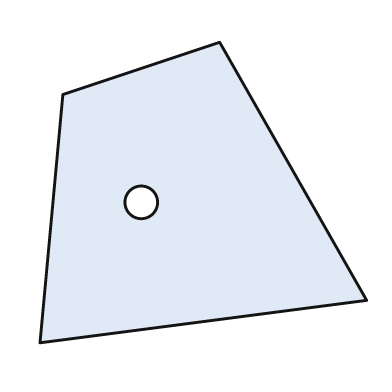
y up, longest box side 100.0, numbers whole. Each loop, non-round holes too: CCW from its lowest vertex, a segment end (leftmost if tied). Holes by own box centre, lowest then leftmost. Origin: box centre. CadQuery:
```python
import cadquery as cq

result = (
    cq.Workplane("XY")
    .moveTo(-50.0, -46.0)
    .lineTo(50.0, -33.0)
    .lineTo(5.0, 46.0)
    .lineTo(-43.0, 30.0)
    .close()
    .moveTo(-19.0, -3.0)
    .circle(5.0)
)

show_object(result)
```